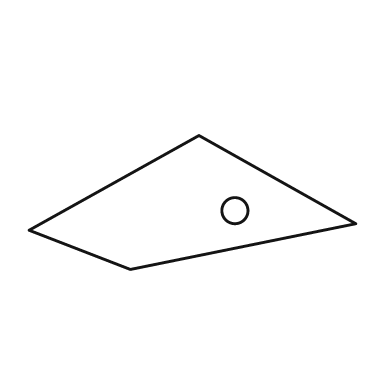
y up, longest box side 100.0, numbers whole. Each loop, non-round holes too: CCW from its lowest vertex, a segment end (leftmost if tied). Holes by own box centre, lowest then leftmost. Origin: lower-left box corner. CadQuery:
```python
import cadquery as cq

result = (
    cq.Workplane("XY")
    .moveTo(31.0, 0.0)
    .lineTo(100.0, 14.0)
    .lineTo(52.0, 41.0)
    .lineTo(0.0, 12.0)
    .close()
    .moveTo(63.0, 18.0)
    .circle(4.0)
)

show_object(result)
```